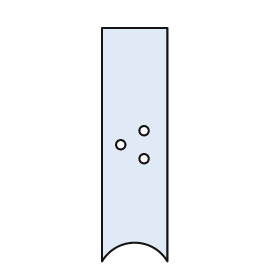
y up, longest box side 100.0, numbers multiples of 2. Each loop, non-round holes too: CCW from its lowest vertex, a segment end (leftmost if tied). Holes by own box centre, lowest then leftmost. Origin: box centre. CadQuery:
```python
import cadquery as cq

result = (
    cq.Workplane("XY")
    .moveTo(-14.0, -50.0)
    .threePointArc((0.0, -42.0), (14.0, -50.0))
    .lineTo(14.0, 50.0)
    .lineTo(-14.0, 50.0)
    .close()
    .moveTo(4.0, -6.0)
    .circle(2.0)
    .moveTo(-6.0, 0.0)
    .circle(2.0)
    .moveTo(4.0, 6.0)
    .circle(2.0)
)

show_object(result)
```